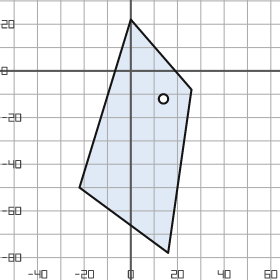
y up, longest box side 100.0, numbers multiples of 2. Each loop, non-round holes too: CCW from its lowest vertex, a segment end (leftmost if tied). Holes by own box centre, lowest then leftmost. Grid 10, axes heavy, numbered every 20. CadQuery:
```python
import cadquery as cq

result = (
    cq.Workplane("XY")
    .moveTo(16.0, -78.0)
    .lineTo(26.0, -8.0)
    .lineTo(0.0, 22.0)
    .lineTo(-22.0, -50.0)
    .close()
    .moveTo(14.0, -12.0)
    .circle(2.0)
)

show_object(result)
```